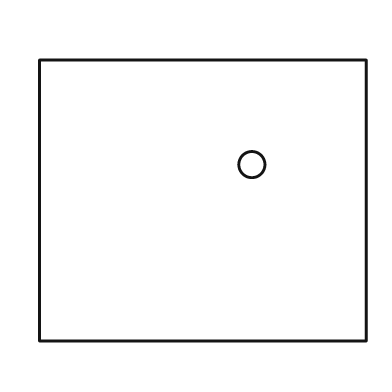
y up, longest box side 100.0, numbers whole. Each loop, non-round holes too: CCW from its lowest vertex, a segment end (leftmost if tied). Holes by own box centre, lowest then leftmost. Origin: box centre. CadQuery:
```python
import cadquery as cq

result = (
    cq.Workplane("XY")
    .moveTo(-50.0, -43.0)
    .lineTo(50.0, -43.0)
    .lineTo(50.0, 43.0)
    .lineTo(-50.0, 43.0)
    .close()
    .moveTo(15.0, 11.0)
    .circle(4.0)
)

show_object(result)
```